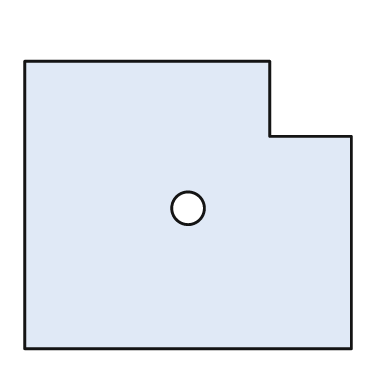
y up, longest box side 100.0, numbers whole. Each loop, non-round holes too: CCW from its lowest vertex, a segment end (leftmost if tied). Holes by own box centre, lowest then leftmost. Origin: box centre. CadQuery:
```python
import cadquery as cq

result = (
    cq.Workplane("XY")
    .moveTo(-50.0, -44.0)
    .lineTo(50.0, -44.0)
    .lineTo(50.0, 21.0)
    .lineTo(25.0, 21.0)
    .lineTo(25.0, 44.0)
    .lineTo(-50.0, 44.0)
    .close()
    .moveTo(0.0, -1.0)
    .circle(5.0)
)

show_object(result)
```